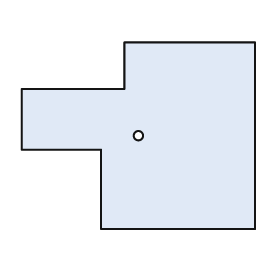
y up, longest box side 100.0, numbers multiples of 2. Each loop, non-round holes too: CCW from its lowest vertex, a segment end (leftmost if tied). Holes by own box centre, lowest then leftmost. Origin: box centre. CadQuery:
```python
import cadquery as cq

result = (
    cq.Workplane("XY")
    .moveTo(-16.0, -40.0)
    .lineTo(50.0, -40.0)
    .lineTo(50.0, 40.0)
    .lineTo(-6.0, 40.0)
    .lineTo(-6.0, 20.0)
    .lineTo(-50.0, 20.0)
    .lineTo(-50.0, -6.0)
    .lineTo(-16.0, -6.0)
    .close()
    .moveTo(0.0, 0.0)
    .circle(2.0)
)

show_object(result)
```